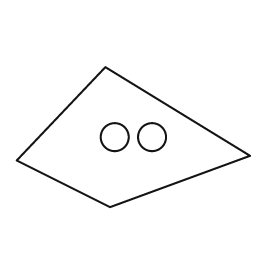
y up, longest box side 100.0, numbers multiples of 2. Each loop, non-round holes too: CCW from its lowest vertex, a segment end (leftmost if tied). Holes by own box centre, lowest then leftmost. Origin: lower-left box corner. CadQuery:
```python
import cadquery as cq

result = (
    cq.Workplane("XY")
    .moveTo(40.0, 0.0)
    .lineTo(100.0, 22.0)
    .lineTo(38.0, 60.0)
    .lineTo(0.0, 20.0)
    .close()
    .moveTo(42.0, 30.0)
    .circle(6.0)
    .moveTo(58.0, 30.0)
    .circle(6.0)
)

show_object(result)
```